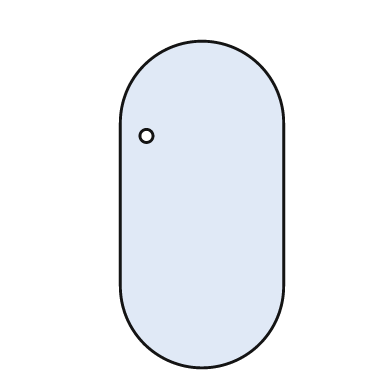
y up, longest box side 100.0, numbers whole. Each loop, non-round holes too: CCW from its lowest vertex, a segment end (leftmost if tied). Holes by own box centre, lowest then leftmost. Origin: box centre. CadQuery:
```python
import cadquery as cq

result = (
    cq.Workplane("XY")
    .moveTo(-25.0, -25.0)
    .threePointArc((0.0, -50.0), (25.0, -25.0))
    .lineTo(25.0, 25.0)
    .threePointArc((0.0, 50.0), (-25.0, 25.0))
    .close()
    .moveTo(-17.0, 21.0)
    .circle(2.0)
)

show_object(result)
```